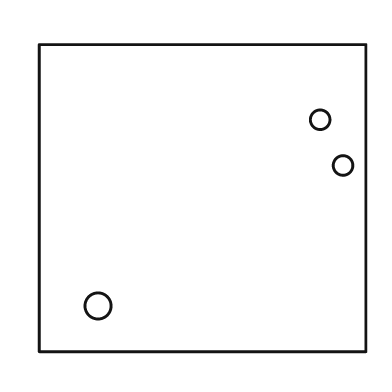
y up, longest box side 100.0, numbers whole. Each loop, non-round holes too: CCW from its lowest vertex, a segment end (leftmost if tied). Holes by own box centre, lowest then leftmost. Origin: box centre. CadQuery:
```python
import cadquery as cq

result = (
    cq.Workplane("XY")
    .moveTo(-50.0, -47.0)
    .lineTo(50.0, -47.0)
    .lineTo(50.0, 47.0)
    .lineTo(-50.0, 47.0)
    .close()
    .moveTo(-32.0, -33.0)
    .circle(4.0)
    .moveTo(43.0, 10.0)
    .circle(3.0)
    .moveTo(36.0, 24.0)
    .circle(3.0)
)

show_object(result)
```